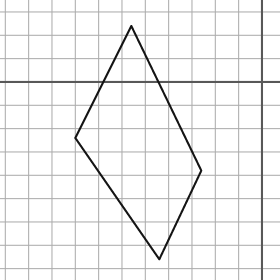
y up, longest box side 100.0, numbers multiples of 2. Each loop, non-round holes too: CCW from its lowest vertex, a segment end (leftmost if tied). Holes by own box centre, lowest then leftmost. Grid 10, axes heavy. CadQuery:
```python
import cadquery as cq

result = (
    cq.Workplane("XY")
    .moveTo(-44.0, -76.0)
    .lineTo(-26.0, -38.0)
    .lineTo(-56.0, 24.0)
    .lineTo(-80.0, -24.0)
    .close()
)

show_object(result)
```